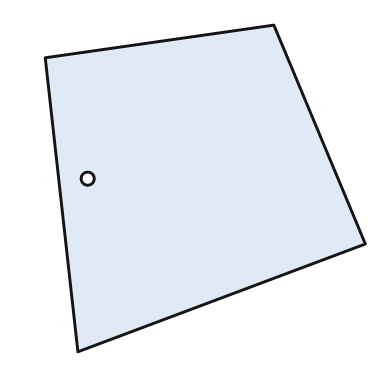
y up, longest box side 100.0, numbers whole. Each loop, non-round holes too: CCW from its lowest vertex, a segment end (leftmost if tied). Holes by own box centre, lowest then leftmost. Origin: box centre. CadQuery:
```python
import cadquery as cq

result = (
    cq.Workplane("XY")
    .moveTo(-39.0, -50.0)
    .lineTo(49.0, -17.0)
    .lineTo(21.0, 50.0)
    .lineTo(-49.0, 40.0)
    .close()
    .moveTo(-36.0, 3.0)
    .circle(2.0)
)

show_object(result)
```